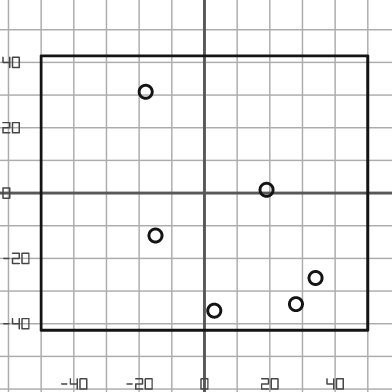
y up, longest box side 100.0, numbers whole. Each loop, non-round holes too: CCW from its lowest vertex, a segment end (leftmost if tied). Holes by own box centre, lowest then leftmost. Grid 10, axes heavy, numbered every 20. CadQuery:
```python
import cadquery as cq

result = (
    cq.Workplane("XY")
    .moveTo(-50.0, -42.0)
    .lineTo(50.0, -42.0)
    .lineTo(50.0, 42.0)
    .lineTo(-50.0, 42.0)
    .close()
    .moveTo(3.0, -36.0)
    .circle(2.0)
    .moveTo(28.0, -34.0)
    .circle(2.0)
    .moveTo(34.0, -26.0)
    .circle(2.0)
    .moveTo(-15.0, -13.0)
    .circle(2.0)
    .moveTo(19.0, 1.0)
    .circle(2.0)
    .moveTo(-18.0, 31.0)
    .circle(2.0)
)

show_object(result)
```